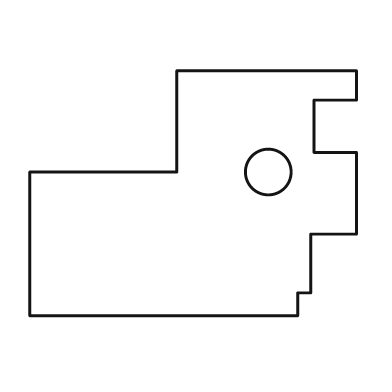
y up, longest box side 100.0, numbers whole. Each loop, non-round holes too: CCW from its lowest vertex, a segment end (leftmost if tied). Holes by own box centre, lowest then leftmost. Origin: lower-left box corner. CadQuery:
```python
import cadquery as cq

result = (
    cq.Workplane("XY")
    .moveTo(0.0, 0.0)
    .lineTo(82.0, 0.0)
    .lineTo(82.0, 7.0)
    .lineTo(86.0, 7.0)
    .lineTo(86.0, 25.0)
    .lineTo(100.0, 25.0)
    .lineTo(100.0, 50.0)
    .lineTo(87.0, 50.0)
    .lineTo(87.0, 66.0)
    .lineTo(100.0, 66.0)
    .lineTo(100.0, 75.0)
    .lineTo(45.0, 75.0)
    .lineTo(45.0, 44.0)
    .lineTo(0.0, 44.0)
    .close()
    .moveTo(73.0, 44.0)
    .circle(7.0)
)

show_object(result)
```